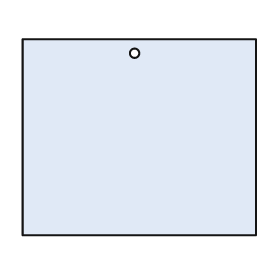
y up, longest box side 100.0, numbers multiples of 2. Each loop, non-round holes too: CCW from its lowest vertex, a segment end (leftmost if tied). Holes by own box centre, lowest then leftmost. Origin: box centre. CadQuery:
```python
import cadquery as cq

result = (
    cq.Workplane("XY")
    .moveTo(-50.0, -42.0)
    .lineTo(50.0, -42.0)
    .lineTo(50.0, 42.0)
    .lineTo(-50.0, 42.0)
    .close()
    .moveTo(-2.0, 36.0)
    .circle(2.0)
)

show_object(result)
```